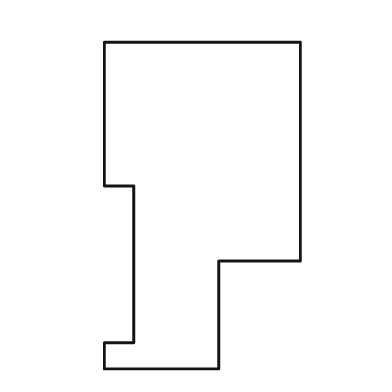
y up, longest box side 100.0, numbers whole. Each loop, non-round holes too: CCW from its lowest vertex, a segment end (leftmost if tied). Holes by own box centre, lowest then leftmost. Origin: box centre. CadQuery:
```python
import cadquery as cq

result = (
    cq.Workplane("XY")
    .moveTo(-30.0, -50.0)
    .lineTo(5.0, -50.0)
    .lineTo(5.0, -17.0)
    .lineTo(30.0, -17.0)
    .lineTo(30.0, 50.0)
    .lineTo(-30.0, 50.0)
    .lineTo(-30.0, 6.0)
    .lineTo(-21.0, 6.0)
    .lineTo(-21.0, -42.0)
    .lineTo(-30.0, -42.0)
    .close()
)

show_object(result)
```